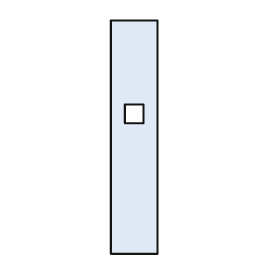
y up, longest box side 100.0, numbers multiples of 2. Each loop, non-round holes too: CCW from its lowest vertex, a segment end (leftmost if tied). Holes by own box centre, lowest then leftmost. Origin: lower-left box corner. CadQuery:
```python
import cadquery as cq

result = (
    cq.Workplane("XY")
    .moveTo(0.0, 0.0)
    .lineTo(20.0, 0.0)
    .lineTo(20.0, 100.0)
    .lineTo(0.0, 100.0)
    .close()
    .moveTo(6.0, 56.0)
    .lineTo(14.0, 56.0)
    .lineTo(14.0, 64.0)
    .lineTo(6.0, 64.0)
    .close()
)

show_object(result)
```